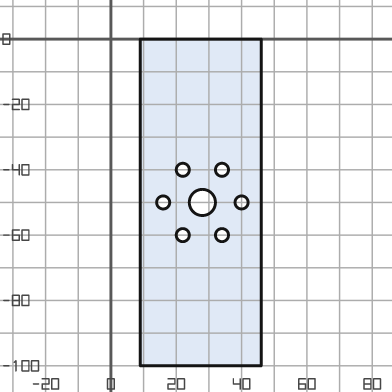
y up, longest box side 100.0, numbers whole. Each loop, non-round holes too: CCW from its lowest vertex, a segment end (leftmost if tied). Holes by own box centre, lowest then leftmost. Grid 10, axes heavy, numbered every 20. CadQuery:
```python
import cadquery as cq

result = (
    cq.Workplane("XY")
    .moveTo(9.0, -100.0)
    .lineTo(46.0, -100.0)
    .lineTo(46.0, 0.0)
    .lineTo(9.0, 0.0)
    .close()
    .moveTo(22.0, -60.0)
    .circle(2.0)
    .moveTo(34.0, -60.0)
    .circle(2.0)
    .moveTo(16.0, -50.0)
    .circle(2.0)
    .moveTo(28.0, -50.0)
    .circle(4.0)
    .moveTo(40.0, -50.0)
    .circle(2.0)
    .moveTo(22.0, -40.0)
    .circle(2.0)
    .moveTo(34.0, -40.0)
    .circle(2.0)
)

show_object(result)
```